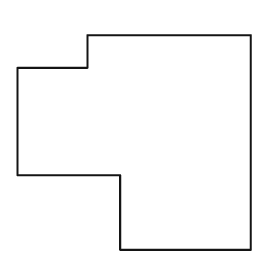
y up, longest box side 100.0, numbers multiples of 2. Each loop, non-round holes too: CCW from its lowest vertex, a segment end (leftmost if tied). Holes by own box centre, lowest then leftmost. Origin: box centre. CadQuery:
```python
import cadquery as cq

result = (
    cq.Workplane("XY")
    .moveTo(-6.0, -46.0)
    .lineTo(50.0, -46.0)
    .lineTo(50.0, 46.0)
    .lineTo(-20.0, 46.0)
    .lineTo(-20.0, 32.0)
    .lineTo(-50.0, 32.0)
    .lineTo(-50.0, -14.0)
    .lineTo(-6.0, -14.0)
    .close()
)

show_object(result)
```